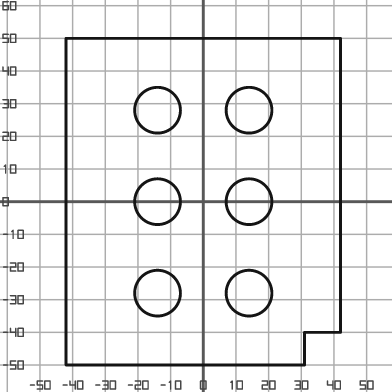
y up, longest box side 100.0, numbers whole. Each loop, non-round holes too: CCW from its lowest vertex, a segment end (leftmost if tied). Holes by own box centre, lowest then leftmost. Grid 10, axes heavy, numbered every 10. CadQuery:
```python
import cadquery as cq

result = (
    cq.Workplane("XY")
    .moveTo(-42.0, -50.0)
    .lineTo(31.0, -50.0)
    .lineTo(31.0, -40.0)
    .lineTo(42.0, -40.0)
    .lineTo(42.0, 50.0)
    .lineTo(-42.0, 50.0)
    .close()
    .moveTo(-14.0, -28.0)
    .circle(7.0)
    .moveTo(14.0, -28.0)
    .circle(7.0)
    .moveTo(-14.0, 0.0)
    .circle(7.0)
    .moveTo(14.0, 0.0)
    .circle(7.0)
    .moveTo(-14.0, 28.0)
    .circle(7.0)
    .moveTo(14.0, 28.0)
    .circle(7.0)
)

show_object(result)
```